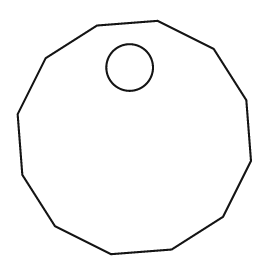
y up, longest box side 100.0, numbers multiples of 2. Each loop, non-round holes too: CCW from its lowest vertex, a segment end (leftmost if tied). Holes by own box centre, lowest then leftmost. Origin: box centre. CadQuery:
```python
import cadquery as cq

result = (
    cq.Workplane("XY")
    .moveTo(-10.0, -50.0)
    .lineTo(16.0, -48.0)
    .lineTo(38.0, -34.0)
    .lineTo(50.0, -10.0)
    .lineTo(48.0, 16.0)
    .lineTo(34.0, 38.0)
    .lineTo(10.0, 50.0)
    .lineTo(-16.0, 48.0)
    .lineTo(-38.0, 34.0)
    .lineTo(-50.0, 10.0)
    .lineTo(-48.0, -16.0)
    .lineTo(-34.0, -38.0)
    .close()
    .moveTo(-2.0, 30.0)
    .circle(10.0)
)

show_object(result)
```